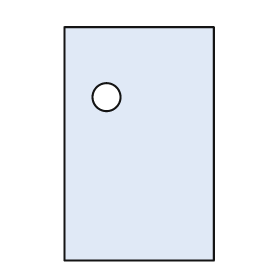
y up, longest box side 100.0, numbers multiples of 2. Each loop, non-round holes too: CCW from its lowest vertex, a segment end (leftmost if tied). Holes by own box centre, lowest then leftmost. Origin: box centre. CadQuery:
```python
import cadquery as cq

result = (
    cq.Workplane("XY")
    .moveTo(-32.0, -50.0)
    .lineTo(32.0, -50.0)
    .lineTo(32.0, 50.0)
    .lineTo(-32.0, 50.0)
    .close()
    .moveTo(-14.0, 20.0)
    .circle(6.0)
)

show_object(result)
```